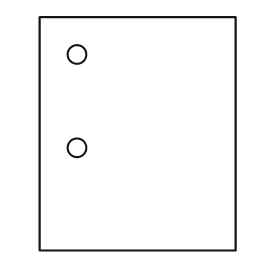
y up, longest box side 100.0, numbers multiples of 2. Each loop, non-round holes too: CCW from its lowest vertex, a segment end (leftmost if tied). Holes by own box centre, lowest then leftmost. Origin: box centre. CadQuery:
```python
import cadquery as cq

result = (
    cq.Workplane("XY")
    .moveTo(-42.0, -50.0)
    .lineTo(42.0, -50.0)
    .lineTo(42.0, 50.0)
    .lineTo(-42.0, 50.0)
    .close()
    .moveTo(-26.0, -6.0)
    .circle(4.0)
    .moveTo(-26.0, 34.0)
    .circle(4.0)
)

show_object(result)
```